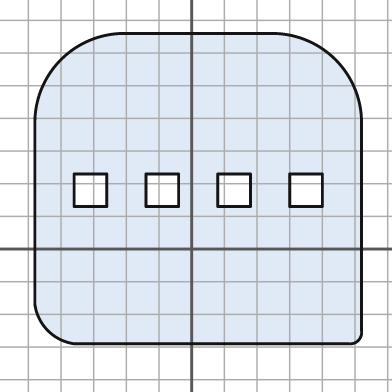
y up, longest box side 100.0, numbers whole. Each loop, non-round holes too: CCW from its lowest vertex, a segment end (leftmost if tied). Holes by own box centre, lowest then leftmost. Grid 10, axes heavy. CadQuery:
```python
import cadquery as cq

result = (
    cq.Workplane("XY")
    .moveTo(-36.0, -29.0)
    .lineTo(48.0, -29.0)
    .threePointArc((51.0, -28.0), (52.0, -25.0))
    .lineTo(52.0, 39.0)
    .threePointArc((44.0, 58.0), (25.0, 66.0))
    .lineTo(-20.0, 66.0)
    .threePointArc((-40.0, 58.0), (-48.0, 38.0))
    .lineTo(-48.0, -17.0)
    .threePointArc((-44.0, -25.0), (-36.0, -29.0))
    .close()
    .moveTo(-36.0, 13.0)
    .lineTo(-26.0, 13.0)
    .lineTo(-26.0, 23.0)
    .lineTo(-36.0, 23.0)
    .close()
    .moveTo(-14.0, 13.0)
    .lineTo(-4.0, 13.0)
    .lineTo(-4.0, 23.0)
    .lineTo(-14.0, 23.0)
    .close()
    .moveTo(8.0, 13.0)
    .lineTo(18.0, 13.0)
    .lineTo(18.0, 23.0)
    .lineTo(8.0, 23.0)
    .close()
    .moveTo(30.0, 13.0)
    .lineTo(40.0, 13.0)
    .lineTo(40.0, 23.0)
    .lineTo(30.0, 23.0)
    .close()
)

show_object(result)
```